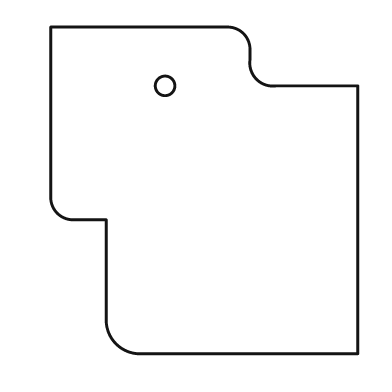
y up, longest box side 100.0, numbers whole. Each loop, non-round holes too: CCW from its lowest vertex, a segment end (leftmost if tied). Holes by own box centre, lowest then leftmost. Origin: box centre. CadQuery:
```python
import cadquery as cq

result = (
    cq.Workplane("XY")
    .moveTo(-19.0, -50.0)
    .lineTo(47.0, -50.0)
    .lineTo(47.0, 32.0)
    .lineTo(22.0, 32.0)
    .threePointArc((16.0, 34.0), (14.0, 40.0))
    .lineTo(14.0, 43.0)
    .threePointArc((12.0, 48.0), (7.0, 50.0))
    .lineTo(-47.0, 50.0)
    .lineTo(-47.0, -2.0)
    .threePointArc((-45.0, -7.0), (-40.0, -9.0))
    .lineTo(-30.0, -9.0)
    .lineTo(-30.0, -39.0)
    .threePointArc((-27.0, -47.0), (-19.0, -50.0))
    .close()
    .moveTo(-12.0, 32.0)
    .circle(3.0)
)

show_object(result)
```